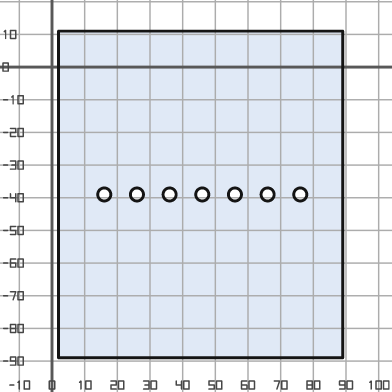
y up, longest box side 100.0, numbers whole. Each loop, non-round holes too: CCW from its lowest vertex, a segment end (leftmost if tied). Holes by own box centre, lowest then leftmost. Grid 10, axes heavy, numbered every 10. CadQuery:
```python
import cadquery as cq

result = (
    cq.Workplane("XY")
    .moveTo(2.0, -89.0)
    .lineTo(89.0, -89.0)
    .lineTo(89.0, 11.0)
    .lineTo(2.0, 11.0)
    .close()
    .moveTo(16.0, -39.0)
    .circle(2.0)
    .moveTo(26.0, -39.0)
    .circle(2.0)
    .moveTo(36.0, -39.0)
    .circle(2.0)
    .moveTo(46.0, -39.0)
    .circle(2.0)
    .moveTo(56.0, -39.0)
    .circle(2.0)
    .moveTo(66.0, -39.0)
    .circle(2.0)
    .moveTo(76.0, -39.0)
    .circle(2.0)
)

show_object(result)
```